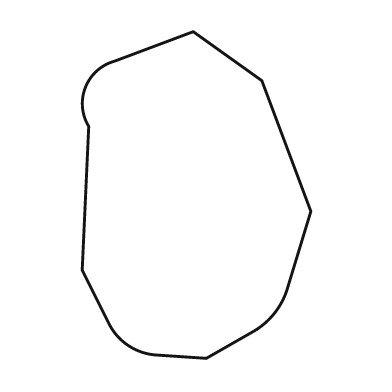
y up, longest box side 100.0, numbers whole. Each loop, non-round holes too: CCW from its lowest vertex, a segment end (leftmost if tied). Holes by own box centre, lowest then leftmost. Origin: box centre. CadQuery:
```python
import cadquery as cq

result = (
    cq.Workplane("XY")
    .moveTo(3.0, -50.0)
    .lineTo(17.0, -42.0)
    .threePointArc((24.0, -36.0), (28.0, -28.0))
    .lineTo(35.0, -5.0)
    .lineTo(20.0, 35.0)
    .lineTo(-1.0, 50.0)
    .lineTo(-25.0, 41.0)
    .threePointArc((-34.0, 33.0), (-33.0, 21.0))
    .lineTo(-35.0, -23.0)
    .lineTo(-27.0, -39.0)
    .threePointArc((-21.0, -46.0), (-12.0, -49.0))
    .close()
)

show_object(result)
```